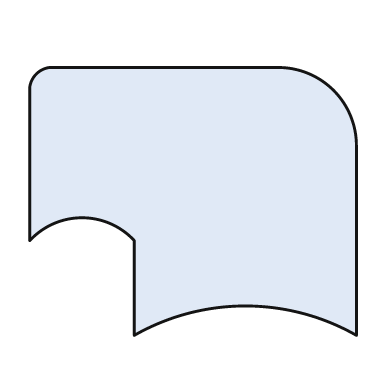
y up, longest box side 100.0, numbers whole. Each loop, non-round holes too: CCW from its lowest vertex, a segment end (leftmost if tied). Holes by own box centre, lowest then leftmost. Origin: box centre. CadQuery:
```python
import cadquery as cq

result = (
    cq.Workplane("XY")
    .moveTo(-18.0, -41.0)
    .threePointArc((16.0, -32.0), (50.0, -41.0))
    .lineTo(50.0, 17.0)
    .threePointArc((43.0, 34.0), (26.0, 41.0))
    .lineTo(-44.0, 41.0)
    .threePointArc((-48.0, 39.0), (-50.0, 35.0))
    .lineTo(-50.0, -12.0)
    .threePointArc((-34.0, -5.0), (-18.0, -12.0))
    .close()
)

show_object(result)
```